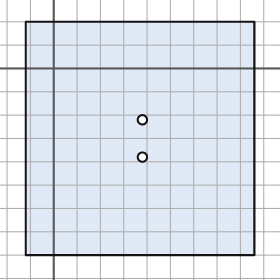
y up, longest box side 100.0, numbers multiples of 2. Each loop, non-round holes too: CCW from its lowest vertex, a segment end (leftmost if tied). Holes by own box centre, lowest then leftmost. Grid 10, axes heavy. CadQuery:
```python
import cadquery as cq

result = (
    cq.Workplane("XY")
    .moveTo(-12.0, -80.0)
    .lineTo(86.0, -80.0)
    .lineTo(86.0, 20.0)
    .lineTo(-12.0, 20.0)
    .close()
    .moveTo(38.0, -38.0)
    .circle(2.0)
    .moveTo(38.0, -22.0)
    .circle(2.0)
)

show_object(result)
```